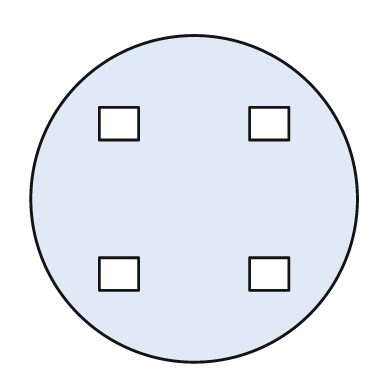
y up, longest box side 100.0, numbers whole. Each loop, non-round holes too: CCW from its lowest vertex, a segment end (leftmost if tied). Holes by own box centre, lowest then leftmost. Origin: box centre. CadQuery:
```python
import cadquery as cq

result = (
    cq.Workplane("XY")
    .moveTo(0.0, 0.0)
    .circle(50.0)
    .moveTo(-29.0, -28.0)
    .lineTo(-17.0, -28.0)
    .lineTo(-17.0, -18.0)
    .lineTo(-29.0, -18.0)
    .close()
    .moveTo(17.0, -28.0)
    .lineTo(29.0, -28.0)
    .lineTo(29.0, -18.0)
    .lineTo(17.0, -18.0)
    .close()
    .moveTo(-29.0, 18.0)
    .lineTo(-17.0, 18.0)
    .lineTo(-17.0, 28.0)
    .lineTo(-29.0, 28.0)
    .close()
    .moveTo(17.0, 18.0)
    .lineTo(29.0, 18.0)
    .lineTo(29.0, 28.0)
    .lineTo(17.0, 28.0)
    .close()
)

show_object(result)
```